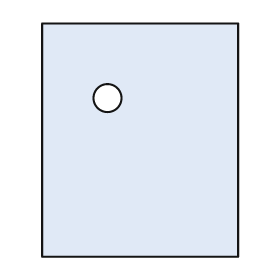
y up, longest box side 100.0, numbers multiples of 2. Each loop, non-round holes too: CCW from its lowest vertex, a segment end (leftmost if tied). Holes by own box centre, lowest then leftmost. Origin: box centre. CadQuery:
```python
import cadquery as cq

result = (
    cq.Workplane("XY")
    .moveTo(-42.0, -50.0)
    .lineTo(42.0, -50.0)
    .lineTo(42.0, 50.0)
    .lineTo(-42.0, 50.0)
    .close()
    .moveTo(-14.0, 18.0)
    .circle(6.0)
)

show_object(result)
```